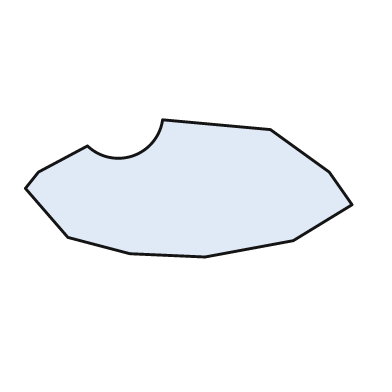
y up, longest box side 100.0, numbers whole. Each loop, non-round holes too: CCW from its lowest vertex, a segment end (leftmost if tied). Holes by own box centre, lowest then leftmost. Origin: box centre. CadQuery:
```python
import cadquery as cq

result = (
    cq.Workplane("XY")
    .moveTo(5.0, -21.0)
    .lineTo(32.0, -16.0)
    .lineTo(50.0, -5.0)
    .lineTo(43.0, 5.0)
    .lineTo(25.0, 18.0)
    .lineTo(-8.0, 21.0)
    .threePointArc((-17.0, 10.0), (-31.0, 13.0))
    .lineTo(-46.0, 5.0)
    .lineTo(-50.0, 0.0)
    .lineTo(-37.0, -15.0)
    .lineTo(-18.0, -20.0)
    .close()
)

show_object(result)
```